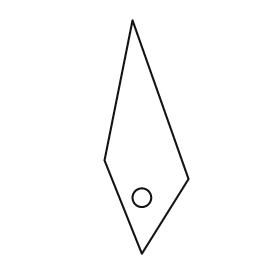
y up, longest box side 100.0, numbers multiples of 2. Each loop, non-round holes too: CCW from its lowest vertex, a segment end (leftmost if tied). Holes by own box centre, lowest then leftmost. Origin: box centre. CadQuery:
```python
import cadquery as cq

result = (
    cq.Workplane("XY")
    .moveTo(-2.0, -50.0)
    .lineTo(18.0, -18.0)
    .lineTo(-6.0, 50.0)
    .lineTo(-18.0, -10.0)
    .close()
    .moveTo(-2.0, -26.0)
    .circle(4.0)
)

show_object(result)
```